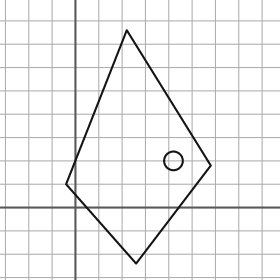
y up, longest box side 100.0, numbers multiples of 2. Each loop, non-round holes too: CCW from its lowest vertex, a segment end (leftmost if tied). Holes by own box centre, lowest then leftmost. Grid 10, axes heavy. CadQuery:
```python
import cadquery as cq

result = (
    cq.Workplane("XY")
    .moveTo(26.0, -24.0)
    .lineTo(58.0, 18.0)
    .lineTo(22.0, 76.0)
    .lineTo(-4.0, 10.0)
    .close()
    .moveTo(42.0, 20.0)
    .circle(4.0)
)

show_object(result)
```